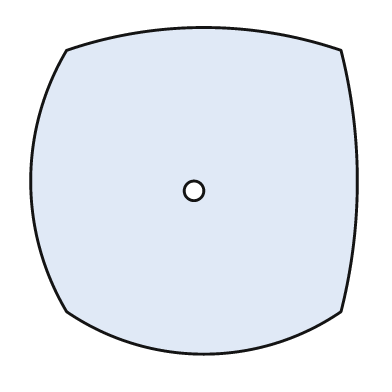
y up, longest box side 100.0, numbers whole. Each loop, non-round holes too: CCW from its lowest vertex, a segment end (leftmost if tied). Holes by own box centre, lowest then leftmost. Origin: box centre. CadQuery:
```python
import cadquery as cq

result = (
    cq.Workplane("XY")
    .moveTo(-39.0, -37.0)
    .threePointArc((3.0, -50.0), (45.0, -37.0))
    .threePointArc((50.0, 3.0), (45.0, 43.0))
    .threePointArc((3.0, 50.0), (-39.0, 43.0))
    .threePointArc((-50.0, 3.0), (-39.0, -37.0))
    .close()
    .moveTo(0.0, 0.0)
    .circle(3.0)
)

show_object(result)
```